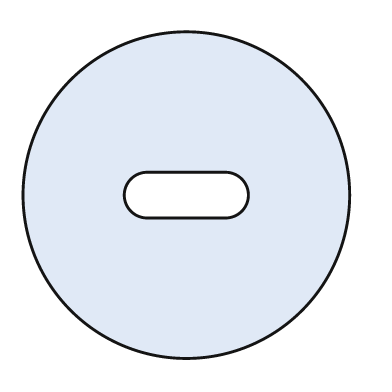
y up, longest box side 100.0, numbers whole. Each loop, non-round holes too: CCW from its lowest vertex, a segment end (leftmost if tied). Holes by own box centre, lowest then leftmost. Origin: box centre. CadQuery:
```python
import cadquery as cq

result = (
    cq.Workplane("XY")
    .moveTo(0.0, 0.0)
    .circle(50.0)
    .moveTo(-12.0, -7.0)
    .lineTo(12.0, -7.0)
    .threePointArc((19.0, 0.0), (12.0, 7.0))
    .lineTo(-12.0, 7.0)
    .threePointArc((-19.0, 0.0), (-12.0, -7.0))
    .close()
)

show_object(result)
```